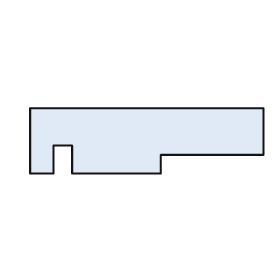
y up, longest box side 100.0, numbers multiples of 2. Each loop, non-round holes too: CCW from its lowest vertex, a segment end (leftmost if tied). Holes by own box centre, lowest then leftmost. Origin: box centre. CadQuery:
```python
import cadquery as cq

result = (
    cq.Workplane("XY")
    .moveTo(-50.0, -14.0)
    .lineTo(-40.0, -14.0)
    .lineTo(-40.0, -2.0)
    .lineTo(-32.0, -2.0)
    .lineTo(-32.0, -14.0)
    .lineTo(6.0, -14.0)
    .lineTo(6.0, -6.0)
    .lineTo(50.0, -6.0)
    .lineTo(50.0, 14.0)
    .lineTo(-50.0, 14.0)
    .close()
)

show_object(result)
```